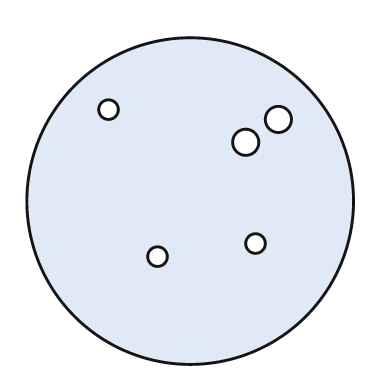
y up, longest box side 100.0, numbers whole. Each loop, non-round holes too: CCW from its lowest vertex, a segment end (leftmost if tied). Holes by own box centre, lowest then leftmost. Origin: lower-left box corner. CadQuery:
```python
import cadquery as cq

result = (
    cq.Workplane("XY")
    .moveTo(50.0, 50.0)
    .circle(50.0)
    .moveTo(40.0, 33.0)
    .circle(3.0)
    .moveTo(70.0, 37.0)
    .circle(3.0)
    .moveTo(67.0, 68.0)
    .circle(4.0)
    .moveTo(77.0, 75.0)
    .circle(4.0)
    .moveTo(25.0, 78.0)
    .circle(3.0)
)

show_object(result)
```